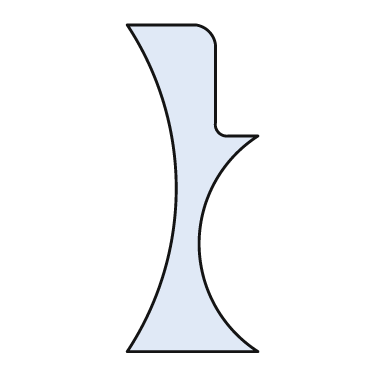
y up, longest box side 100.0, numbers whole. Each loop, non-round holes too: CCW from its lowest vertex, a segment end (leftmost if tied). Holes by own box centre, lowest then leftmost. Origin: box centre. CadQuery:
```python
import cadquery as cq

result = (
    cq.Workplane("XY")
    .moveTo(-20.0, -50.0)
    .lineTo(20.0, -50.0)
    .threePointArc((2.0, -17.0), (20.0, 16.0))
    .lineTo(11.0, 16.0)
    .threePointArc((8.0, 17.0), (7.0, 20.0))
    .lineTo(7.0, 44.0)
    .threePointArc((5.0, 48.0), (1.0, 50.0))
    .lineTo(-20.0, 50.0)
    .threePointArc((-5.0, 0.0), (-20.0, -50.0))
    .close()
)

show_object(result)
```